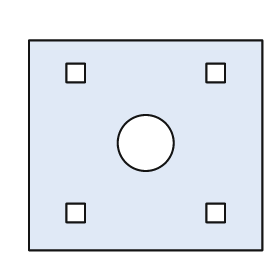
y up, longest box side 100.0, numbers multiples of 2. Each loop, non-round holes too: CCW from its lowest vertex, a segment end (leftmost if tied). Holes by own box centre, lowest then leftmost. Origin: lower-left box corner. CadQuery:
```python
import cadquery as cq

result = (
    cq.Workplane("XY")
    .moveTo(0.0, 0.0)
    .lineTo(100.0, 0.0)
    .lineTo(100.0, 90.0)
    .lineTo(0.0, 90.0)
    .close()
    .moveTo(16.0, 12.0)
    .lineTo(24.0, 12.0)
    .lineTo(24.0, 20.0)
    .lineTo(16.0, 20.0)
    .close()
    .moveTo(76.0, 12.0)
    .lineTo(84.0, 12.0)
    .lineTo(84.0, 20.0)
    .lineTo(76.0, 20.0)
    .close()
    .moveTo(50.0, 46.0)
    .circle(12.0)
    .moveTo(16.0, 72.0)
    .lineTo(24.0, 72.0)
    .lineTo(24.0, 80.0)
    .lineTo(16.0, 80.0)
    .close()
    .moveTo(76.0, 72.0)
    .lineTo(84.0, 72.0)
    .lineTo(84.0, 80.0)
    .lineTo(76.0, 80.0)
    .close()
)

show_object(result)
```